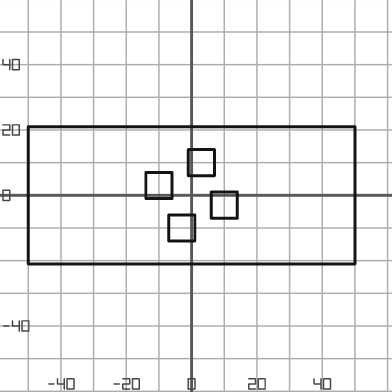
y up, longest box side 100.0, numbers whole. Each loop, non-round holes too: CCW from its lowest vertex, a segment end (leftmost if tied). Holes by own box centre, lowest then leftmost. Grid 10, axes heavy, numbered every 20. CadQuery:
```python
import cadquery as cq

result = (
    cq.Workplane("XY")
    .moveTo(-50.0, -21.0)
    .lineTo(50.0, -21.0)
    .lineTo(50.0, 21.0)
    .lineTo(-50.0, 21.0)
    .close()
    .moveTo(-7.0, -14.0)
    .lineTo(1.0, -14.0)
    .lineTo(1.0, -6.0)
    .lineTo(-7.0, -6.0)
    .close()
    .moveTo(6.0, -7.0)
    .lineTo(14.0, -7.0)
    .lineTo(14.0, 1.0)
    .lineTo(6.0, 1.0)
    .close()
    .moveTo(-14.0, -1.0)
    .lineTo(-6.0, -1.0)
    .lineTo(-6.0, 7.0)
    .lineTo(-14.0, 7.0)
    .close()
    .moveTo(-1.0, 6.0)
    .lineTo(7.0, 6.0)
    .lineTo(7.0, 14.0)
    .lineTo(-1.0, 14.0)
    .close()
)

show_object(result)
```